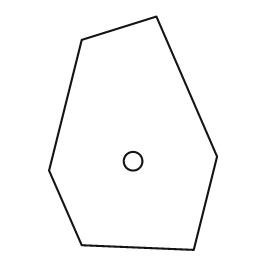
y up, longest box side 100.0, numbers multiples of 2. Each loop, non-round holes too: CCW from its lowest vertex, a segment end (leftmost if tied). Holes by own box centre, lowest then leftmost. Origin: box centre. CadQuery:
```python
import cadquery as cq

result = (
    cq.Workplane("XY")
    .moveTo(26.0, -50.0)
    .lineTo(36.0, -10.0)
    .lineTo(10.0, 50.0)
    .lineTo(-22.0, 40.0)
    .lineTo(-36.0, -16.0)
    .lineTo(-22.0, -48.0)
    .close()
    .moveTo(0.0, -12.0)
    .circle(4.0)
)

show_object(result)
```